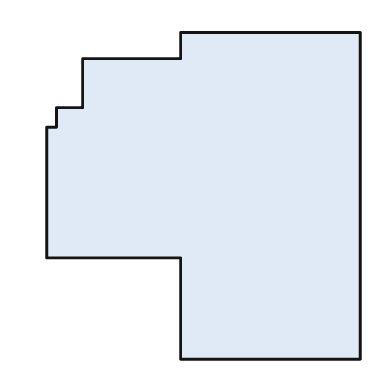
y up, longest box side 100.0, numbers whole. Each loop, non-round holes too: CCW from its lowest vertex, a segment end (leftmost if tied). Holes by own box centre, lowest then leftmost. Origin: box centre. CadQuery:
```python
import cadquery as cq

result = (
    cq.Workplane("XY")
    .moveTo(-7.0, -50.0)
    .lineTo(48.0, -50.0)
    .lineTo(48.0, 50.0)
    .lineTo(-7.0, 50.0)
    .lineTo(-7.0, 42.0)
    .lineTo(-37.0, 42.0)
    .lineTo(-37.0, 27.0)
    .lineTo(-45.0, 27.0)
    .lineTo(-45.0, 21.0)
    .lineTo(-48.0, 21.0)
    .lineTo(-48.0, -19.0)
    .lineTo(-7.0, -19.0)
    .close()
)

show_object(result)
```